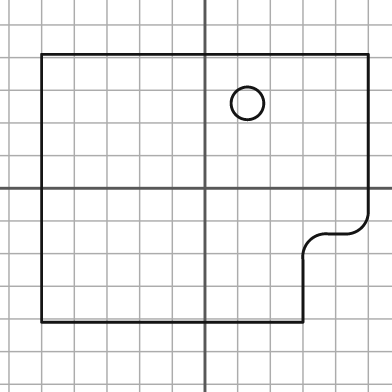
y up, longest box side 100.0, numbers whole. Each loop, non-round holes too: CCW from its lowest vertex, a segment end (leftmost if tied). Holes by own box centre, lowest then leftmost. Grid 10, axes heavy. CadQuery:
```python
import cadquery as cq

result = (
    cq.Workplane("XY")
    .moveTo(-50.0, -41.0)
    .lineTo(30.0, -41.0)
    .lineTo(30.0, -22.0)
    .threePointArc((32.0, -16.0), (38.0, -14.0))
    .lineTo(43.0, -14.0)
    .threePointArc((48.0, -12.0), (50.0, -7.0))
    .lineTo(50.0, 41.0)
    .lineTo(-50.0, 41.0)
    .close()
    .moveTo(13.0, 26.0)
    .circle(5.0)
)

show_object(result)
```